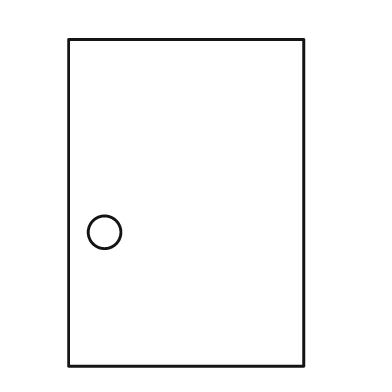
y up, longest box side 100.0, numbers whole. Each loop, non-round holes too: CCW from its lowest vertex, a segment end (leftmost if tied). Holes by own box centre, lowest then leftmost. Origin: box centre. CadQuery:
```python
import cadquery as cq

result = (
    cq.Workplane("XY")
    .moveTo(-36.0, -50.0)
    .lineTo(36.0, -50.0)
    .lineTo(36.0, 50.0)
    .lineTo(-36.0, 50.0)
    .close()
    .moveTo(-25.0, -9.0)
    .circle(5.0)
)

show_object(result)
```